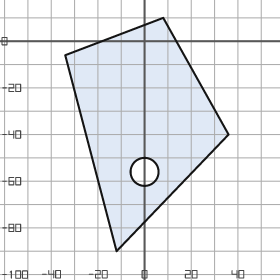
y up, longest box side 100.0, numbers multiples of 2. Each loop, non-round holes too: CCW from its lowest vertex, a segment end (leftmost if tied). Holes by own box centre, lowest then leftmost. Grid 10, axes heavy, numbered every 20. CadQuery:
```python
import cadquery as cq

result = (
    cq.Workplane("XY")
    .moveTo(-12.0, -90.0)
    .lineTo(36.0, -40.0)
    .lineTo(8.0, 10.0)
    .lineTo(-34.0, -6.0)
    .close()
    .moveTo(0.0, -56.0)
    .circle(6.0)
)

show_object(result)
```